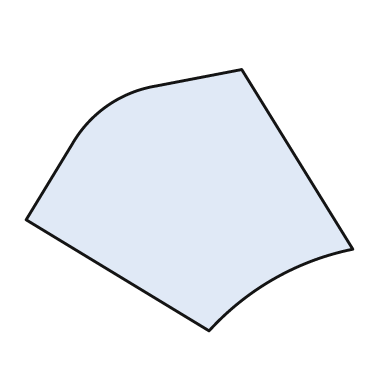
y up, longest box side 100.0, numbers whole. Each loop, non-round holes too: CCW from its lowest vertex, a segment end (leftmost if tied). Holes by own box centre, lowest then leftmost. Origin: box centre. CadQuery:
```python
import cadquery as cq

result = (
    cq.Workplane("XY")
    .moveTo(6.0, -40.0)
    .threePointArc((26.0, -24.0), (50.0, -15.0))
    .lineTo(16.0, 40.0)
    .lineTo(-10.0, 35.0)
    .threePointArc((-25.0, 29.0), (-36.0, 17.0))
    .lineTo(-50.0, -6.0)
    .close()
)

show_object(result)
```